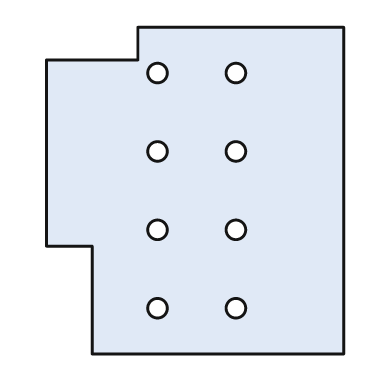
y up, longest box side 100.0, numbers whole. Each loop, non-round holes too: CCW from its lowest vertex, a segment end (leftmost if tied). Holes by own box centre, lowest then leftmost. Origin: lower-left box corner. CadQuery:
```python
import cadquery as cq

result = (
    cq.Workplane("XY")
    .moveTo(14.0, 0.0)
    .lineTo(91.0, 0.0)
    .lineTo(91.0, 100.0)
    .lineTo(28.0, 100.0)
    .lineTo(28.0, 90.0)
    .lineTo(0.0, 90.0)
    .lineTo(0.0, 33.0)
    .lineTo(14.0, 33.0)
    .close()
    .moveTo(34.0, 14.0)
    .circle(3.0)
    .moveTo(58.0, 14.0)
    .circle(3.0)
    .moveTo(34.0, 38.0)
    .circle(3.0)
    .moveTo(58.0, 38.0)
    .circle(3.0)
    .moveTo(34.0, 62.0)
    .circle(3.0)
    .moveTo(58.0, 62.0)
    .circle(3.0)
    .moveTo(34.0, 86.0)
    .circle(3.0)
    .moveTo(58.0, 86.0)
    .circle(3.0)
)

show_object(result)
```